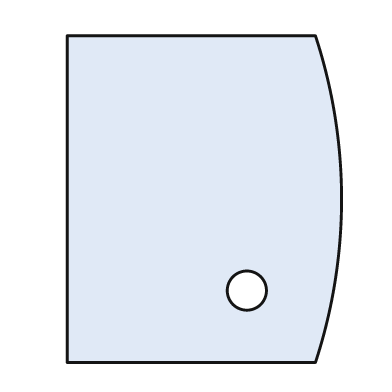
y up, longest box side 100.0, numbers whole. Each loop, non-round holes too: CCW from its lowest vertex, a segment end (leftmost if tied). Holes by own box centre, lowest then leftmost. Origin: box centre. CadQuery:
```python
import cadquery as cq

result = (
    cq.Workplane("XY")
    .moveTo(-42.0, -50.0)
    .lineTo(34.0, -50.0)
    .threePointArc((42.0, 0.0), (34.0, 50.0))
    .lineTo(-42.0, 50.0)
    .close()
    .moveTo(13.0, -28.0)
    .circle(6.0)
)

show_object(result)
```